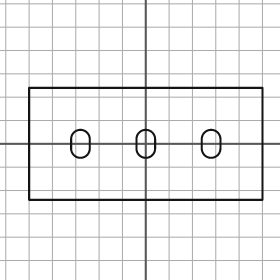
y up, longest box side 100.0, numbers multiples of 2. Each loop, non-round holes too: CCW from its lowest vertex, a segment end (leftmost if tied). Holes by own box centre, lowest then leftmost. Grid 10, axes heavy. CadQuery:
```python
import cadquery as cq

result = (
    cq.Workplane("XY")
    .moveTo(-50.0, -24.0)
    .lineTo(50.0, -24.0)
    .lineTo(50.0, 24.0)
    .lineTo(-50.0, 24.0)
    .close()
    .moveTo(-32.0, -2.0)
    .threePointArc((-28.0, -6.0), (-24.0, -2.0))
    .lineTo(-24.0, 2.0)
    .threePointArc((-28.0, 6.0), (-32.0, 2.0))
    .close()
    .moveTo(-4.0, -2.0)
    .threePointArc((0.0, -6.0), (4.0, -2.0))
    .lineTo(4.0, 2.0)
    .threePointArc((0.0, 6.0), (-4.0, 2.0))
    .close()
    .moveTo(24.0, -2.0)
    .threePointArc((28.0, -6.0), (32.0, -2.0))
    .lineTo(32.0, 2.0)
    .threePointArc((28.0, 6.0), (24.0, 2.0))
    .close()
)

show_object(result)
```